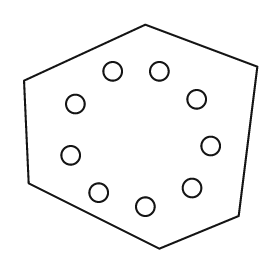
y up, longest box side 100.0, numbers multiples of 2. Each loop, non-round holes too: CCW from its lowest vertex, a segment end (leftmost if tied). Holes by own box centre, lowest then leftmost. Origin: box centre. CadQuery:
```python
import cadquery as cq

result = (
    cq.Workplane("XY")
    .moveTo(8.0, -48.0)
    .lineTo(42.0, -34.0)
    .lineTo(50.0, 30.0)
    .lineTo(2.0, 48.0)
    .lineTo(-50.0, 24.0)
    .lineTo(-48.0, -20.0)
    .close()
    .moveTo(2.0, -30.0)
    .circle(4.0)
    .moveTo(-18.0, -24.0)
    .circle(4.0)
    .moveTo(22.0, -22.0)
    .circle(4.0)
    .moveTo(-30.0, -8.0)
    .circle(4.0)
    .moveTo(30.0, -4.0)
    .circle(4.0)
    .moveTo(-28.0, 14.0)
    .circle(4.0)
    .moveTo(24.0, 16.0)
    .circle(4.0)
    .moveTo(-12.0, 28.0)
    .circle(4.0)
    .moveTo(8.0, 28.0)
    .circle(4.0)
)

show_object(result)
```